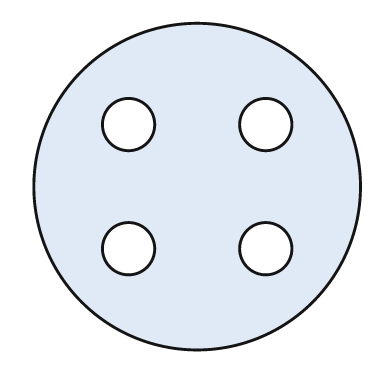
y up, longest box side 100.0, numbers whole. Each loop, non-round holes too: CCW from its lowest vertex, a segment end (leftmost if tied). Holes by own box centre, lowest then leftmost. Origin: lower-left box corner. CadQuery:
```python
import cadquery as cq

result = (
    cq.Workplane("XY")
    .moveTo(50.0, 50.0)
    .circle(50.0)
    .moveTo(29.0, 31.0)
    .circle(8.0)
    .moveTo(71.0, 31.0)
    .circle(8.0)
    .moveTo(29.0, 69.0)
    .circle(8.0)
    .moveTo(71.0, 69.0)
    .circle(8.0)
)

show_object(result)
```